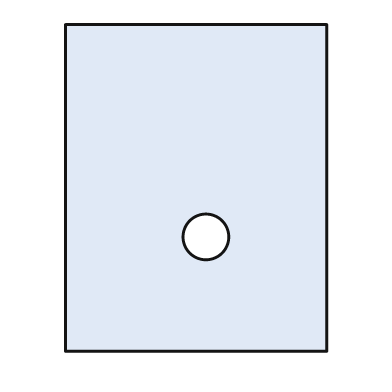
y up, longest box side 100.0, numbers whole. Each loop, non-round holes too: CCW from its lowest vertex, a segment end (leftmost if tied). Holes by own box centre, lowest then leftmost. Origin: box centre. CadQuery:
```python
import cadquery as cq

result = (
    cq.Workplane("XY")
    .moveTo(-40.0, -50.0)
    .lineTo(40.0, -50.0)
    .lineTo(40.0, 50.0)
    .lineTo(-40.0, 50.0)
    .close()
    .moveTo(3.0, -15.0)
    .circle(7.0)
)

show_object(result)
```